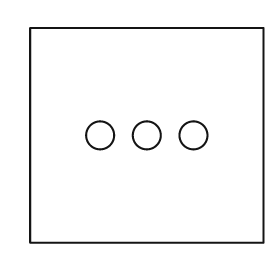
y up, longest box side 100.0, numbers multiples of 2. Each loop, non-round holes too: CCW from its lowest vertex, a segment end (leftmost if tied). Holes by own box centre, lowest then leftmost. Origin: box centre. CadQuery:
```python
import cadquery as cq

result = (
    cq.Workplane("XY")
    .moveTo(-50.0, -46.0)
    .lineTo(50.0, -46.0)
    .lineTo(50.0, 46.0)
    .lineTo(-50.0, 46.0)
    .close()
    .moveTo(-20.0, 0.0)
    .circle(6.0)
    .moveTo(0.0, 0.0)
    .circle(6.0)
    .moveTo(20.0, 0.0)
    .circle(6.0)
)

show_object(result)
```